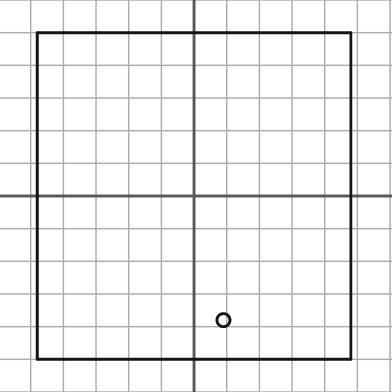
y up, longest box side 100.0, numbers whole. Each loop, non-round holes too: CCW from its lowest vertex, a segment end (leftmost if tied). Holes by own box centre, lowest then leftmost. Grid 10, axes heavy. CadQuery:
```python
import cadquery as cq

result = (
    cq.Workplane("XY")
    .moveTo(-48.0, -50.0)
    .lineTo(48.0, -50.0)
    .lineTo(48.0, 50.0)
    .lineTo(-48.0, 50.0)
    .close()
    .moveTo(9.0, -38.0)
    .circle(2.0)
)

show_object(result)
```